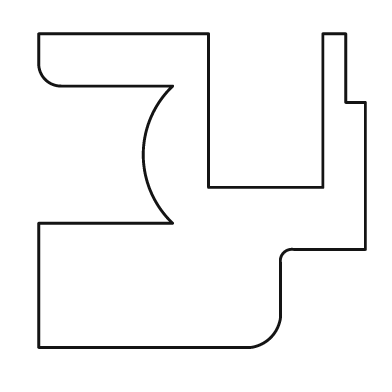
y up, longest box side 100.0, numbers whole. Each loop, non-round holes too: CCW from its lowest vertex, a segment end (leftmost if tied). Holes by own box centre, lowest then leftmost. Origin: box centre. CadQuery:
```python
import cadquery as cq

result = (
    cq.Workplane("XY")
    .moveTo(-50.0, -48.0)
    .lineTo(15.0, -48.0)
    .threePointArc((21.0, -45.0), (24.0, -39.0))
    .lineTo(24.0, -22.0)
    .threePointArc((25.0, -19.0), (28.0, -18.0))
    .lineTo(50.0, -18.0)
    .lineTo(50.0, 27.0)
    .lineTo(44.0, 27.0)
    .lineTo(44.0, 48.0)
    .lineTo(37.0, 48.0)
    .lineTo(37.0, 1.0)
    .lineTo(2.0, 1.0)
    .lineTo(2.0, 48.0)
    .lineTo(-50.0, 48.0)
    .lineTo(-50.0, 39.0)
    .threePointArc((-48.0, 34.0), (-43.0, 32.0))
    .lineTo(-9.0, 32.0)
    .threePointArc((-18.0, 11.0), (-9.0, -10.0))
    .lineTo(-50.0, -10.0)
    .close()
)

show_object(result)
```